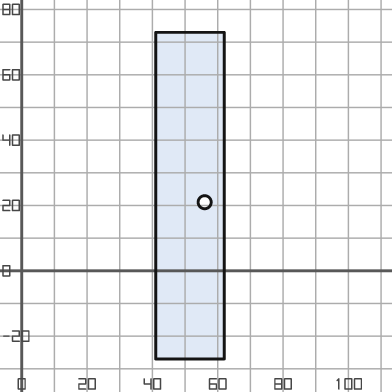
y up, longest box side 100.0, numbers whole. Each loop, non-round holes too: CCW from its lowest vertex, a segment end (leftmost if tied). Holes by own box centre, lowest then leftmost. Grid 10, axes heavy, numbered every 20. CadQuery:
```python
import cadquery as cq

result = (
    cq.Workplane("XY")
    .moveTo(41.0, -27.0)
    .lineTo(62.0, -27.0)
    .lineTo(62.0, 73.0)
    .lineTo(41.0, 73.0)
    .close()
    .moveTo(56.0, 21.0)
    .circle(2.0)
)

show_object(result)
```